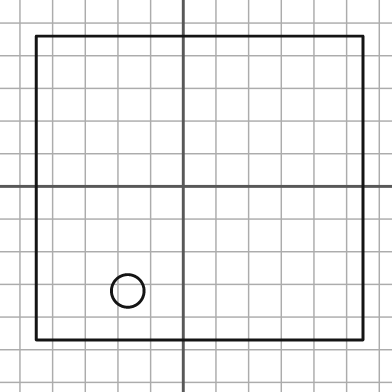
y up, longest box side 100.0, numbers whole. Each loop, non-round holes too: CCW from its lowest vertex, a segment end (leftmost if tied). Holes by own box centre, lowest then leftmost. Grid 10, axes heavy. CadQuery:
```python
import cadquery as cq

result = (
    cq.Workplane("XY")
    .moveTo(-45.0, -47.0)
    .lineTo(55.0, -47.0)
    .lineTo(55.0, 46.0)
    .lineTo(-45.0, 46.0)
    .close()
    .moveTo(-17.0, -32.0)
    .circle(5.0)
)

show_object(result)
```